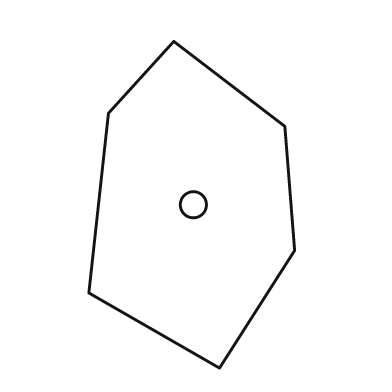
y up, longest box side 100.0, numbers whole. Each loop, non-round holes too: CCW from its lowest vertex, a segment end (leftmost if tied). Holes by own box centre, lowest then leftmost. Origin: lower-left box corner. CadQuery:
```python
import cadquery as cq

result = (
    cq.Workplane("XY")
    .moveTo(40.0, 0.0)
    .lineTo(63.0, 36.0)
    .lineTo(60.0, 74.0)
    .lineTo(26.0, 100.0)
    .lineTo(6.0, 78.0)
    .lineTo(0.0, 23.0)
    .close()
    .moveTo(32.0, 50.0)
    .circle(4.0)
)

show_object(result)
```